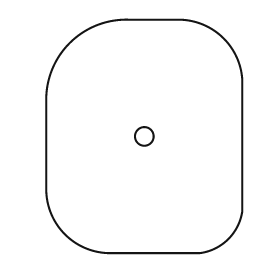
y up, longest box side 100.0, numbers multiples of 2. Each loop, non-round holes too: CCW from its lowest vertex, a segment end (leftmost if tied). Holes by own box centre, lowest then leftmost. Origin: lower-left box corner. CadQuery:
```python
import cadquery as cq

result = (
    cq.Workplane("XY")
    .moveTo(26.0, 0.0)
    .lineTo(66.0, 0.0)
    .threePointArc((78.0, 6.0), (84.0, 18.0))
    .lineTo(84.0, 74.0)
    .threePointArc((76.0, 92.0), (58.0, 100.0))
    .lineTo(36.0, 100.0)
    .threePointArc((10.0, 90.0), (0.0, 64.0))
    .lineTo(0.0, 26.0)
    .threePointArc((8.0, 8.0), (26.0, 0.0))
    .close()
    .moveTo(42.0, 50.0)
    .circle(4.0)
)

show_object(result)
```